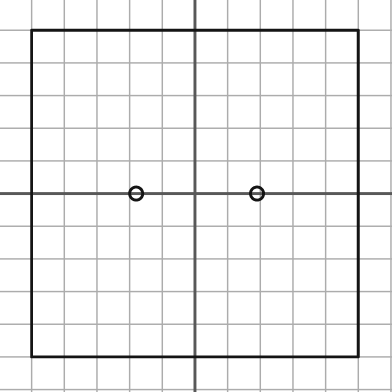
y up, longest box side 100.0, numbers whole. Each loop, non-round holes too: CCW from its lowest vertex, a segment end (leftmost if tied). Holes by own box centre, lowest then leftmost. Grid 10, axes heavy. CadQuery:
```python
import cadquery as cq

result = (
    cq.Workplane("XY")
    .moveTo(-50.0, -50.0)
    .lineTo(50.0, -50.0)
    .lineTo(50.0, 50.0)
    .lineTo(-50.0, 50.0)
    .close()
    .moveTo(-18.0, 0.0)
    .circle(2.0)
    .moveTo(19.0, 0.0)
    .circle(2.0)
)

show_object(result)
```